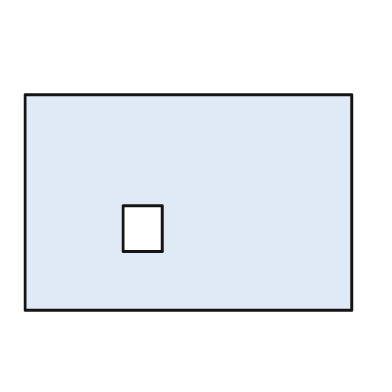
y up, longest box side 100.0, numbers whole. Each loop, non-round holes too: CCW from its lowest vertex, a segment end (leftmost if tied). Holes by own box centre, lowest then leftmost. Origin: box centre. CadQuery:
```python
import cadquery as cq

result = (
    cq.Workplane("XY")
    .moveTo(-50.0, -33.0)
    .lineTo(50.0, -33.0)
    .lineTo(50.0, 33.0)
    .lineTo(-50.0, 33.0)
    .close()
    .moveTo(-20.0, -15.0)
    .lineTo(-8.0, -15.0)
    .lineTo(-8.0, -1.0)
    .lineTo(-20.0, -1.0)
    .close()
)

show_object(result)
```